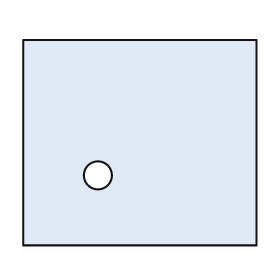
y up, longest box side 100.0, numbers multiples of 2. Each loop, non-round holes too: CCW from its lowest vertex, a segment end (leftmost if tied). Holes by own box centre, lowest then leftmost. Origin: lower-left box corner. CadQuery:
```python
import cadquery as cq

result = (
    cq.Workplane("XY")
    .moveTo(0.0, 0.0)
    .lineTo(100.0, 0.0)
    .lineTo(100.0, 88.0)
    .lineTo(0.0, 88.0)
    .close()
    .moveTo(32.0, 30.0)
    .circle(6.0)
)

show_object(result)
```